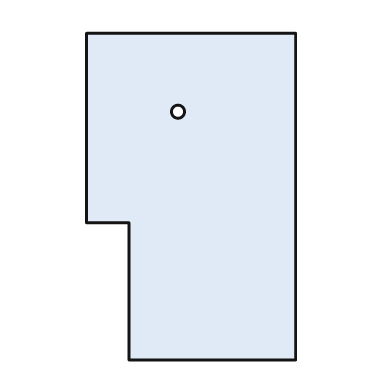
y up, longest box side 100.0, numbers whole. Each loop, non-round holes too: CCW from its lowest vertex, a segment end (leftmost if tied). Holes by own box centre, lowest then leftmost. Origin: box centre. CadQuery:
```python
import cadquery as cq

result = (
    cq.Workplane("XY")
    .moveTo(-19.0, -50.0)
    .lineTo(32.0, -50.0)
    .lineTo(32.0, 50.0)
    .lineTo(-32.0, 50.0)
    .lineTo(-32.0, -8.0)
    .lineTo(-19.0, -8.0)
    .close()
    .moveTo(-4.0, 26.0)
    .circle(2.0)
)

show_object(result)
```